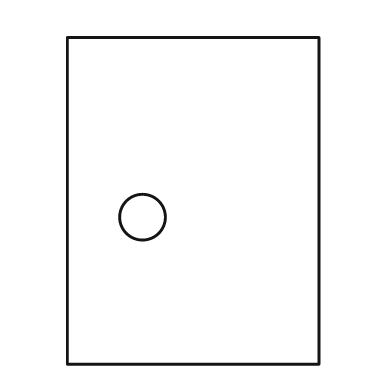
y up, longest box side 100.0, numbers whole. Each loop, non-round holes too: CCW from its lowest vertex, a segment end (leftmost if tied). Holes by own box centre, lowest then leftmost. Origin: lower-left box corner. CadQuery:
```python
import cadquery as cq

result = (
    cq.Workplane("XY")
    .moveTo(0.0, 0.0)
    .lineTo(77.0, 0.0)
    .lineTo(77.0, 100.0)
    .lineTo(0.0, 100.0)
    .close()
    .moveTo(23.0, 45.0)
    .circle(7.0)
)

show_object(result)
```